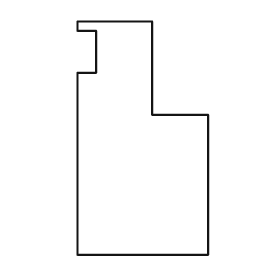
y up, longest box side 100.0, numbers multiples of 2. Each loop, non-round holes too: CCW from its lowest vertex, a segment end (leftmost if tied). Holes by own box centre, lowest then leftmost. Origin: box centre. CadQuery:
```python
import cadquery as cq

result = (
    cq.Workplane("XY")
    .moveTo(-28.0, -50.0)
    .lineTo(28.0, -50.0)
    .lineTo(28.0, 10.0)
    .lineTo(4.0, 10.0)
    .lineTo(4.0, 50.0)
    .lineTo(-28.0, 50.0)
    .lineTo(-28.0, 46.0)
    .lineTo(-20.0, 46.0)
    .lineTo(-20.0, 28.0)
    .lineTo(-28.0, 28.0)
    .close()
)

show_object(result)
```